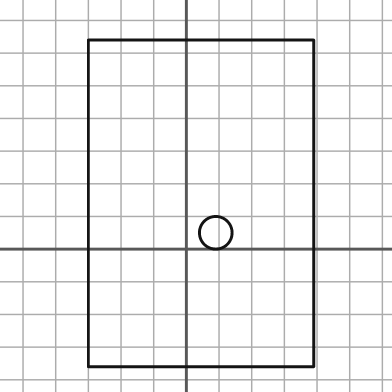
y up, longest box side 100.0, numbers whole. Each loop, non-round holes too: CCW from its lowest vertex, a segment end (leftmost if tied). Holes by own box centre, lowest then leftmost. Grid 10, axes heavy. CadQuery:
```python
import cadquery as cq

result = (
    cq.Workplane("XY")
    .moveTo(-30.0, -36.0)
    .lineTo(39.0, -36.0)
    .lineTo(39.0, 64.0)
    .lineTo(-30.0, 64.0)
    .close()
    .moveTo(9.0, 5.0)
    .circle(5.0)
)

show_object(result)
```